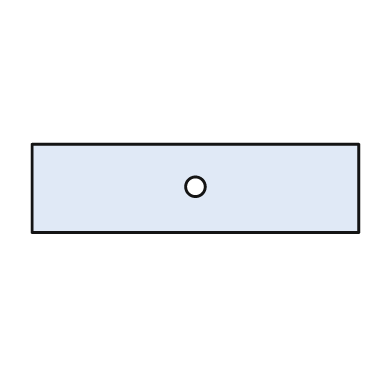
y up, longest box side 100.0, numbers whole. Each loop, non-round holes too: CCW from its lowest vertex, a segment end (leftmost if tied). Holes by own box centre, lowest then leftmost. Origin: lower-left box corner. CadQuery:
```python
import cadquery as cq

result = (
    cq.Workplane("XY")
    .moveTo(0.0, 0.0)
    .lineTo(100.0, 0.0)
    .lineTo(100.0, 27.0)
    .lineTo(0.0, 27.0)
    .close()
    .moveTo(50.0, 14.0)
    .circle(3.0)
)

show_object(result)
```